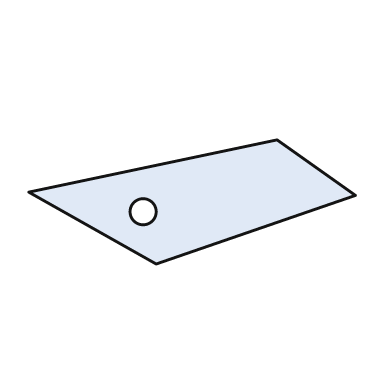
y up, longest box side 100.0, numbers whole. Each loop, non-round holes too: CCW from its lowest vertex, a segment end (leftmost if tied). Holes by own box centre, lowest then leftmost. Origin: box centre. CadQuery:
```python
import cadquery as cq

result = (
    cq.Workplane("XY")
    .moveTo(-11.0, -19.0)
    .lineTo(50.0, 2.0)
    .lineTo(26.0, 19.0)
    .lineTo(-50.0, 3.0)
    .close()
    .moveTo(-15.0, -3.0)
    .circle(4.0)
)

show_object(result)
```